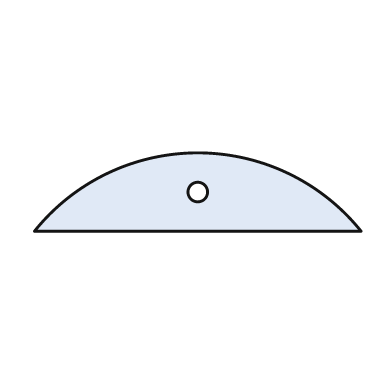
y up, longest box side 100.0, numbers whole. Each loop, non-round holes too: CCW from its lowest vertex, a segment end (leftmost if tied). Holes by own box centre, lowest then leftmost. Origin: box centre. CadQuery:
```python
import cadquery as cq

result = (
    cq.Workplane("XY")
    .moveTo(-50.0, -12.0)
    .lineTo(50.0, -12.0)
    .threePointArc((0.0, 12.0), (-50.0, -12.0))
    .close()
    .moveTo(0.0, 0.0)
    .circle(3.0)
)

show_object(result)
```